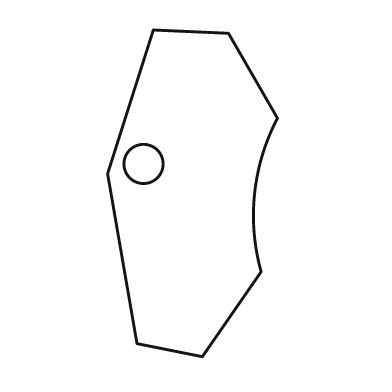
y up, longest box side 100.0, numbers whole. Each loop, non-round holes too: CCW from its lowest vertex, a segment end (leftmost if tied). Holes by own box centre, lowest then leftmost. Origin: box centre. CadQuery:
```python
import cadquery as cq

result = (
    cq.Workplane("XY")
    .moveTo(3.0, -50.0)
    .lineTo(21.0, -24.0)
    .threePointArc((19.0, 0.0), (26.0, 23.0))
    .lineTo(11.0, 49.0)
    .lineTo(-12.0, 50.0)
    .lineTo(-26.0, 6.0)
    .lineTo(-17.0, -46.0)
    .close()
    .moveTo(-15.0, 9.0)
    .circle(6.0)
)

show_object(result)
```